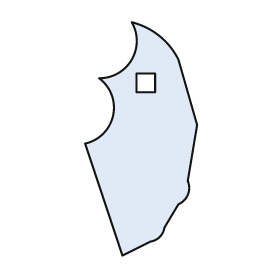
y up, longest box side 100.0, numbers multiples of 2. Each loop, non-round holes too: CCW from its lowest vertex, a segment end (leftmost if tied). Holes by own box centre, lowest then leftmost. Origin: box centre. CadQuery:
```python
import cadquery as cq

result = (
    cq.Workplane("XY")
    .moveTo(-8.0, -50.0)
    .lineTo(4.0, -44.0)
    .threePointArc((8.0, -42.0), (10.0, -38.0))
    .lineTo(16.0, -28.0)
    .threePointArc((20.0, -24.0), (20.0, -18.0))
    .lineTo(24.0, 6.0)
    .lineTo(16.0, 34.0)
    .threePointArc((8.0, 44.0), (-4.0, 50.0))
    .threePointArc((-4.0, 34.0), (-18.0, 26.0))
    .threePointArc((-12.0, 10.0), (-24.0, -2.0))
    .close()
    .moveTo(-2.0, 20.0)
    .lineTo(6.0, 20.0)
    .lineTo(6.0, 28.0)
    .lineTo(-2.0, 28.0)
    .close()
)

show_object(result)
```